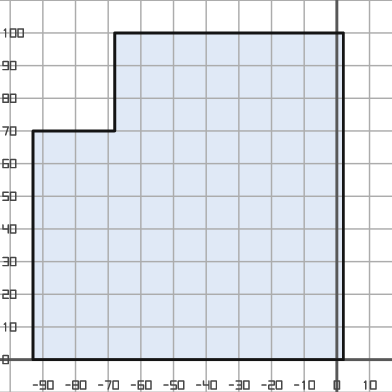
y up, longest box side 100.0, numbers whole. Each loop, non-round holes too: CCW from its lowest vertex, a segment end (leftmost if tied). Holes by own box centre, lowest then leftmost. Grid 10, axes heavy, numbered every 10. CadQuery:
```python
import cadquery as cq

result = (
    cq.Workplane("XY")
    .moveTo(-93.0, 0.0)
    .lineTo(2.0, 0.0)
    .lineTo(2.0, 100.0)
    .lineTo(-68.0, 100.0)
    .lineTo(-68.0, 70.0)
    .lineTo(-93.0, 70.0)
    .close()
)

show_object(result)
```